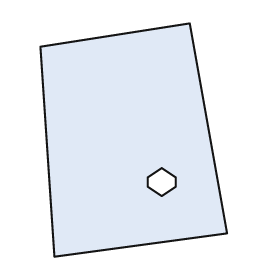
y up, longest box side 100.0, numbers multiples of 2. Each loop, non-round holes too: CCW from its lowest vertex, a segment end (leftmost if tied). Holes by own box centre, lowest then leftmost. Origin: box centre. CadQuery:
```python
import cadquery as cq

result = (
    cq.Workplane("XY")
    .moveTo(-34.0, -50.0)
    .lineTo(40.0, -40.0)
    .lineTo(24.0, 50.0)
    .lineTo(-40.0, 40.0)
    .close()
    .moveTo(12.0, -24.0)
    .lineTo(18.0, -20.0)
    .lineTo(18.0, -16.0)
    .lineTo(12.0, -12.0)
    .lineTo(6.0, -16.0)
    .lineTo(6.0, -20.0)
    .close()
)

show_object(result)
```